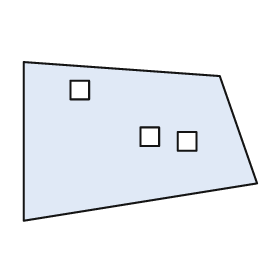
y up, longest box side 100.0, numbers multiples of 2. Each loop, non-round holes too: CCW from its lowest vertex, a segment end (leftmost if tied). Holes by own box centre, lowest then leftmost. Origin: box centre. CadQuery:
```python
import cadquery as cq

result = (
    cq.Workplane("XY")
    .moveTo(-50.0, -34.0)
    .lineTo(50.0, -18.0)
    .lineTo(34.0, 28.0)
    .lineTo(-50.0, 34.0)
    .close()
    .moveTo(16.0, -4.0)
    .lineTo(24.0, -4.0)
    .lineTo(24.0, 4.0)
    .lineTo(16.0, 4.0)
    .close()
    .moveTo(0.0, -2.0)
    .lineTo(8.0, -2.0)
    .lineTo(8.0, 6.0)
    .lineTo(0.0, 6.0)
    .close()
    .moveTo(-30.0, 18.0)
    .lineTo(-22.0, 18.0)
    .lineTo(-22.0, 26.0)
    .lineTo(-30.0, 26.0)
    .close()
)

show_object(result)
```